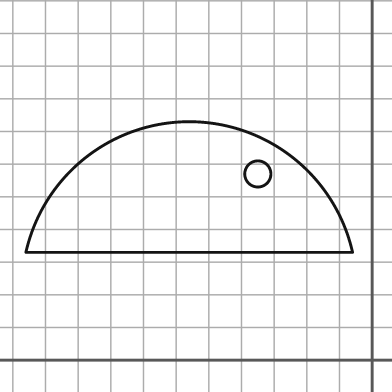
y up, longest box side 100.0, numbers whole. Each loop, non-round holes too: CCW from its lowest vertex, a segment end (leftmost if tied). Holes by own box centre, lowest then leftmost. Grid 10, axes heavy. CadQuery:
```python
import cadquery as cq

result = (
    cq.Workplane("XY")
    .moveTo(-106.0, 33.0)
    .lineTo(-6.0, 33.0)
    .threePointArc((-56.0, 73.0), (-106.0, 33.0))
    .close()
    .moveTo(-35.0, 57.0)
    .circle(4.0)
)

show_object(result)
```